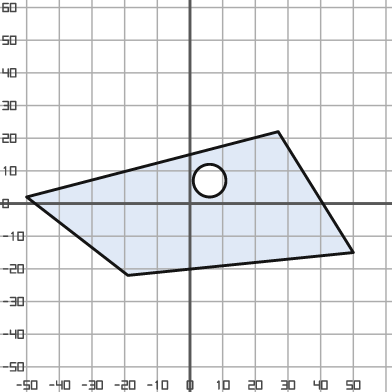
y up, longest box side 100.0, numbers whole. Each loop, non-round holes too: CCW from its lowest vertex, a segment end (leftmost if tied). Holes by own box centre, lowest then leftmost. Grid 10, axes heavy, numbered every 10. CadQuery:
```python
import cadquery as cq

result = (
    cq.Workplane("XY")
    .moveTo(-19.0, -22.0)
    .lineTo(50.0, -15.0)
    .lineTo(27.0, 22.0)
    .lineTo(-50.0, 2.0)
    .close()
    .moveTo(6.0, 7.0)
    .circle(5.0)
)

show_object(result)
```